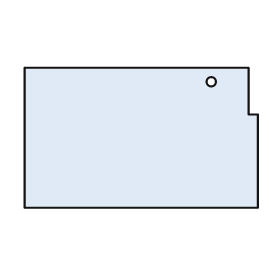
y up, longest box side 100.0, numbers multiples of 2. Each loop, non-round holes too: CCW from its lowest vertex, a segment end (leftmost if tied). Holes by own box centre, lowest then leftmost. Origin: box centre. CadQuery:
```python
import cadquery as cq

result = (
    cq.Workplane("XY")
    .moveTo(-50.0, -30.0)
    .lineTo(50.0, -30.0)
    .lineTo(50.0, 10.0)
    .lineTo(46.0, 10.0)
    .lineTo(46.0, 30.0)
    .lineTo(-50.0, 30.0)
    .close()
    .moveTo(30.0, 24.0)
    .circle(2.0)
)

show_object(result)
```